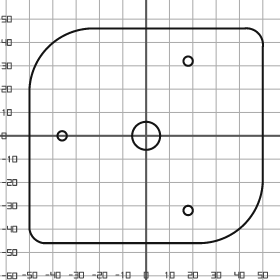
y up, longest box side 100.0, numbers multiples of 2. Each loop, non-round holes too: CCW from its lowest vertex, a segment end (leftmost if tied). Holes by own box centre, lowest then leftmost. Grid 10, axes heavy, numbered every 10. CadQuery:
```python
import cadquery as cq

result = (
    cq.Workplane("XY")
    .moveTo(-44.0, -46.0)
    .lineTo(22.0, -46.0)
    .threePointArc((42.0, -38.0), (50.0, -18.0))
    .lineTo(50.0, 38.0)
    .threePointArc((48.0, 44.0), (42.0, 46.0))
    .lineTo(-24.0, 46.0)
    .threePointArc((-42.0, 38.0), (-50.0, 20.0))
    .lineTo(-50.0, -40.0)
    .threePointArc((-48.0, -44.0), (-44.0, -46.0))
    .close()
    .moveTo(18.0, -32.0)
    .circle(2.0)
    .moveTo(-36.0, 0.0)
    .circle(2.0)
    .moveTo(0.0, 0.0)
    .circle(6.0)
    .moveTo(18.0, 32.0)
    .circle(2.0)
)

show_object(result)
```